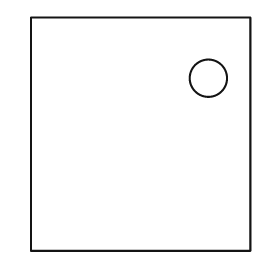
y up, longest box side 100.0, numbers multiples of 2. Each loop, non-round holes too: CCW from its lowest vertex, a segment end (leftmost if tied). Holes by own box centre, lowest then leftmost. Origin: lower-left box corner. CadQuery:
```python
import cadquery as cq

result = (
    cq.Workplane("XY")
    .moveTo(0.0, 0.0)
    .lineTo(94.0, 0.0)
    .lineTo(94.0, 100.0)
    .lineTo(0.0, 100.0)
    .close()
    .moveTo(76.0, 74.0)
    .circle(8.0)
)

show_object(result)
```